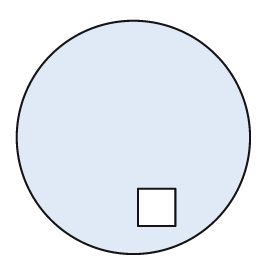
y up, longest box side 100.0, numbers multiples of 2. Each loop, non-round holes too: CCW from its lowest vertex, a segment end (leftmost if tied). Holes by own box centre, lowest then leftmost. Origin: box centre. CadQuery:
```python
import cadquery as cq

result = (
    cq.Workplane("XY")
    .moveTo(0.0, 0.0)
    .circle(50.0)
    .moveTo(2.0, -38.0)
    .lineTo(18.0, -38.0)
    .lineTo(18.0, -22.0)
    .lineTo(2.0, -22.0)
    .close()
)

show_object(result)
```